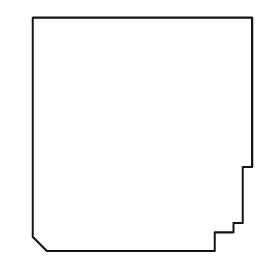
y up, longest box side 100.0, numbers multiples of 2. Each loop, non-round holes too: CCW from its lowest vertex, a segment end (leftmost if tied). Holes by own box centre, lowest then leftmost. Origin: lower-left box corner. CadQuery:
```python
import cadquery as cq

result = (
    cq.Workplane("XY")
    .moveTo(6.0, 0.0)
    .lineTo(78.0, 0.0)
    .lineTo(78.0, 8.0)
    .lineTo(86.0, 8.0)
    .lineTo(86.0, 12.0)
    .lineTo(90.0, 12.0)
    .lineTo(90.0, 36.0)
    .lineTo(94.0, 36.0)
    .lineTo(94.0, 100.0)
    .lineTo(0.0, 100.0)
    .lineTo(0.0, 6.0)
    .close()
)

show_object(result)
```